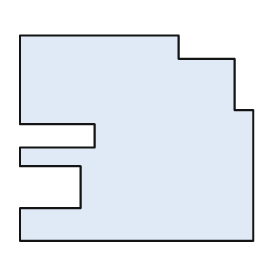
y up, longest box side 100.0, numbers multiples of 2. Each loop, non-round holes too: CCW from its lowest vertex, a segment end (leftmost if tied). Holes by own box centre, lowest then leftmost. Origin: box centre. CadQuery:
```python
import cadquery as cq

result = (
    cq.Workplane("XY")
    .moveTo(-50.0, -44.0)
    .lineTo(50.0, -44.0)
    .lineTo(50.0, 12.0)
    .lineTo(42.0, 12.0)
    .lineTo(42.0, 34.0)
    .lineTo(18.0, 34.0)
    .lineTo(18.0, 44.0)
    .lineTo(-50.0, 44.0)
    .lineTo(-50.0, 6.0)
    .lineTo(-18.0, 6.0)
    .lineTo(-18.0, -4.0)
    .lineTo(-50.0, -4.0)
    .lineTo(-50.0, -12.0)
    .lineTo(-24.0, -12.0)
    .lineTo(-24.0, -30.0)
    .lineTo(-50.0, -30.0)
    .close()
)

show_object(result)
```